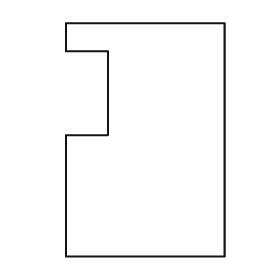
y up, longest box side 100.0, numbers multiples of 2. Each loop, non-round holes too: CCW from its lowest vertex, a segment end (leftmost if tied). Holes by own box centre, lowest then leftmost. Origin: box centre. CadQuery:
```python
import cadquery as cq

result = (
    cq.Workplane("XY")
    .moveTo(-34.0, -50.0)
    .lineTo(34.0, -50.0)
    .lineTo(34.0, 50.0)
    .lineTo(-34.0, 50.0)
    .lineTo(-34.0, 38.0)
    .lineTo(-16.0, 38.0)
    .lineTo(-16.0, 2.0)
    .lineTo(-34.0, 2.0)
    .close()
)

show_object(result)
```